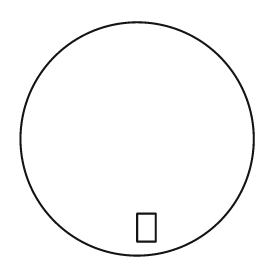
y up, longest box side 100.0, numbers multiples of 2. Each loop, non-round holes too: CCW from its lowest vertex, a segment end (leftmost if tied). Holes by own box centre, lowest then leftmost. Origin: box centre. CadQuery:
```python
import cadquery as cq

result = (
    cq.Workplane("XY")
    .moveTo(0.0, 0.0)
    .circle(50.0)
    .moveTo(0.0, -44.0)
    .lineTo(8.0, -44.0)
    .lineTo(8.0, -32.0)
    .lineTo(0.0, -32.0)
    .close()
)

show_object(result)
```